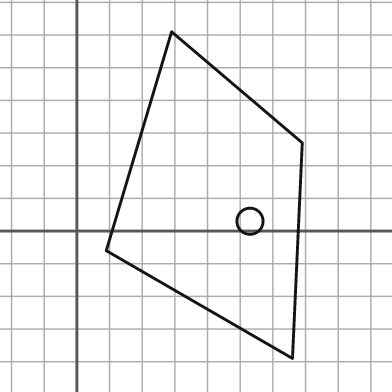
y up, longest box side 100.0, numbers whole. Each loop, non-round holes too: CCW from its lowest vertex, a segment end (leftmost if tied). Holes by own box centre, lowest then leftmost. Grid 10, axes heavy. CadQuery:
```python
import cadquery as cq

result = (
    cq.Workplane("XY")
    .moveTo(66.0, -39.0)
    .lineTo(69.0, 27.0)
    .lineTo(29.0, 61.0)
    .lineTo(9.0, -6.0)
    .close()
    .moveTo(53.0, 3.0)
    .circle(4.0)
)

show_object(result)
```